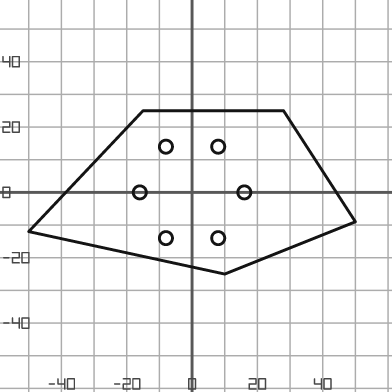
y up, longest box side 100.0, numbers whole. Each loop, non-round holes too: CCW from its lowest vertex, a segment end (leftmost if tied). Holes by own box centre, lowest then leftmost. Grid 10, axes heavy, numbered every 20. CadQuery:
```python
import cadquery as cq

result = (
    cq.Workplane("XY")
    .moveTo(10.0, -25.0)
    .lineTo(50.0, -9.0)
    .lineTo(28.0, 25.0)
    .lineTo(-15.0, 25.0)
    .lineTo(-50.0, -12.0)
    .close()
    .moveTo(-8.0, -14.0)
    .circle(2.0)
    .moveTo(8.0, -14.0)
    .circle(2.0)
    .moveTo(-16.0, 0.0)
    .circle(2.0)
    .moveTo(16.0, 0.0)
    .circle(2.0)
    .moveTo(-8.0, 14.0)
    .circle(2.0)
    .moveTo(8.0, 14.0)
    .circle(2.0)
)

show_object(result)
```